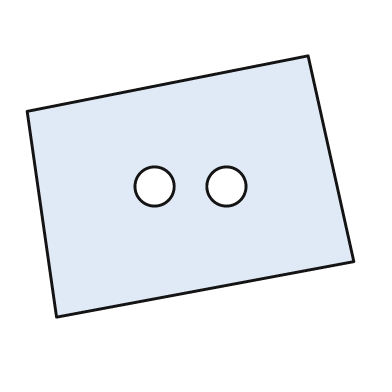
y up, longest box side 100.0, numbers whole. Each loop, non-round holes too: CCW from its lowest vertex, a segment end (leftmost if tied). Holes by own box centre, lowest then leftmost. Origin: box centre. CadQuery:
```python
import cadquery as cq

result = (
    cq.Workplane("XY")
    .moveTo(-41.0, -40.0)
    .lineTo(50.0, -23.0)
    .lineTo(36.0, 40.0)
    .lineTo(-50.0, 23.0)
    .close()
    .moveTo(-11.0, 0.0)
    .circle(6.0)
    .moveTo(11.0, 0.0)
    .circle(6.0)
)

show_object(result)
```